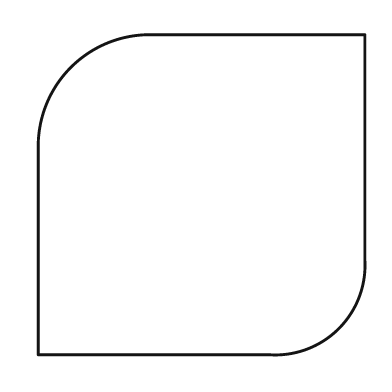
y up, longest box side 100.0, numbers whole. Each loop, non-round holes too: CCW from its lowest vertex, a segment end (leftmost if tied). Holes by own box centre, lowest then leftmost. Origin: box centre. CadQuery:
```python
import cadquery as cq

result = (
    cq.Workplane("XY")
    .moveTo(-50.0, -49.0)
    .lineTo(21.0, -49.0)
    .threePointArc((42.0, -41.0), (50.0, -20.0))
    .lineTo(50.0, 49.0)
    .lineTo(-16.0, 49.0)
    .threePointArc((-40.0, 39.0), (-50.0, 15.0))
    .close()
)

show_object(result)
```